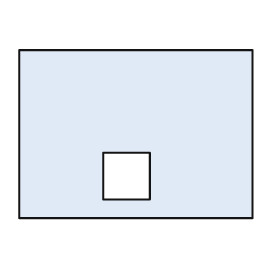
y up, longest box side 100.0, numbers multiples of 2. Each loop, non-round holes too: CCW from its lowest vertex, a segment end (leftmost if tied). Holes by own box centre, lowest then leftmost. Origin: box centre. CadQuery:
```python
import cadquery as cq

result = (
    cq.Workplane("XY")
    .moveTo(-50.0, -36.0)
    .lineTo(50.0, -36.0)
    .lineTo(50.0, 36.0)
    .lineTo(-50.0, 36.0)
    .close()
    .moveTo(-14.0, -28.0)
    .lineTo(6.0, -28.0)
    .lineTo(6.0, -8.0)
    .lineTo(-14.0, -8.0)
    .close()
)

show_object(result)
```